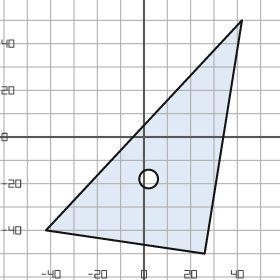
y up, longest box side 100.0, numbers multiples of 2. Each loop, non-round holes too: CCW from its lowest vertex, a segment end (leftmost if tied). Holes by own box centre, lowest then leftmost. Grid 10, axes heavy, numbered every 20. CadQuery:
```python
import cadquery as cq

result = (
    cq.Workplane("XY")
    .moveTo(26.0, -50.0)
    .lineTo(42.0, 50.0)
    .lineTo(-42.0, -40.0)
    .close()
    .moveTo(2.0, -18.0)
    .circle(4.0)
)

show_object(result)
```